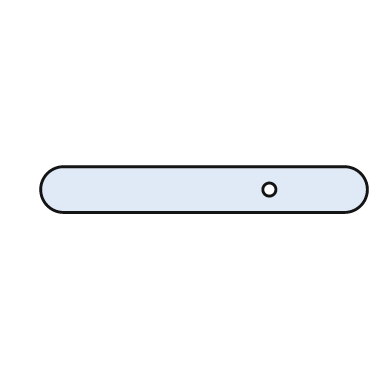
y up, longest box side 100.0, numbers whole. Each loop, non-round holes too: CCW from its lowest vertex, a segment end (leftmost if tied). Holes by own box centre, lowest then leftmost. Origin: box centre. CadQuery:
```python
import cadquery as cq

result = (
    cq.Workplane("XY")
    .moveTo(-43.0, -7.0)
    .lineTo(43.0, -7.0)
    .threePointArc((50.0, 0.0), (43.0, 7.0))
    .lineTo(-43.0, 7.0)
    .threePointArc((-50.0, 0.0), (-43.0, -7.0))
    .close()
    .moveTo(20.0, 0.0)
    .circle(2.0)
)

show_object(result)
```